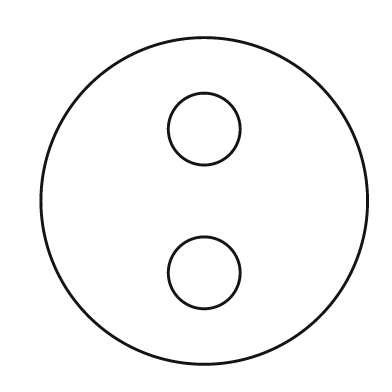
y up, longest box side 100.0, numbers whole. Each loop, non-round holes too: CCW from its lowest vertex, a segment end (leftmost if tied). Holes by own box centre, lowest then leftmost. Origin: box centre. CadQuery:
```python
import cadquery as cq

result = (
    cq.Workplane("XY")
    .moveTo(0.0, 0.0)
    .circle(50.0)
    .moveTo(0.0, -22.0)
    .circle(11.0)
    .moveTo(0.0, 22.0)
    .circle(11.0)
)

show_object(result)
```